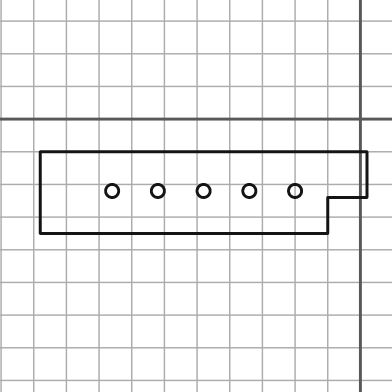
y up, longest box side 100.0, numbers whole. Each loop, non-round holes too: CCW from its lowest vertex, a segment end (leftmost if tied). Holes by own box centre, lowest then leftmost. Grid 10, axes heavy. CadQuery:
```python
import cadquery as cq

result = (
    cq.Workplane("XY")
    .moveTo(-98.0, -35.0)
    .lineTo(-10.0, -35.0)
    .lineTo(-10.0, -24.0)
    .lineTo(2.0, -24.0)
    .lineTo(2.0, -10.0)
    .lineTo(-98.0, -10.0)
    .close()
    .moveTo(-76.0, -22.0)
    .circle(2.0)
    .moveTo(-62.0, -22.0)
    .circle(2.0)
    .moveTo(-48.0, -22.0)
    .circle(2.0)
    .moveTo(-34.0, -22.0)
    .circle(2.0)
    .moveTo(-20.0, -22.0)
    .circle(2.0)
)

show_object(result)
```